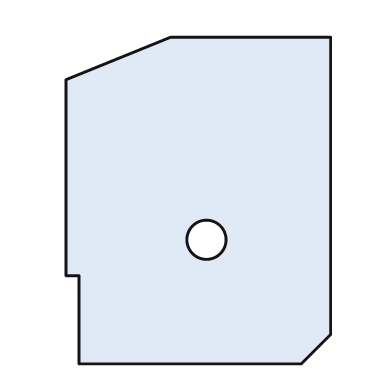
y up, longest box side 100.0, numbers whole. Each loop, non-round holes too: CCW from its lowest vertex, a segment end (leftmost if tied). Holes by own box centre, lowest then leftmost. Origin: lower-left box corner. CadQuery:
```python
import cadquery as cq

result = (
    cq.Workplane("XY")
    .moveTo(4.0, 0.0)
    .lineTo(72.0, 0.0)
    .lineTo(81.0, 9.0)
    .lineTo(81.0, 100.0)
    .lineTo(32.0, 100.0)
    .lineTo(0.0, 87.0)
    .lineTo(0.0, 27.0)
    .lineTo(4.0, 27.0)
    .close()
    .moveTo(43.0, 38.0)
    .circle(6.0)
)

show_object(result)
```